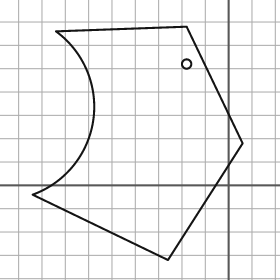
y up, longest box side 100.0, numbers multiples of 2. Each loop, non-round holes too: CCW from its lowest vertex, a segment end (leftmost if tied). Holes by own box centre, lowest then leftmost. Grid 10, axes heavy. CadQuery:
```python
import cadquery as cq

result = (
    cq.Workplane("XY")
    .moveTo(-26.0, -32.0)
    .lineTo(6.0, 18.0)
    .lineTo(-18.0, 68.0)
    .lineTo(-74.0, 66.0)
    .threePointArc((-58.0, 28.0), (-84.0, -4.0))
    .close()
    .moveTo(-18.0, 52.0)
    .circle(2.0)
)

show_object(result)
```